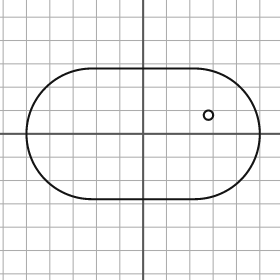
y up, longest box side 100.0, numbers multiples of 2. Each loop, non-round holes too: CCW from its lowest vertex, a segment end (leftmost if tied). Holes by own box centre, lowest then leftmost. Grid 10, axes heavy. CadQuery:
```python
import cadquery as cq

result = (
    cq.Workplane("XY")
    .moveTo(-22.0, -28.0)
    .lineTo(22.0, -28.0)
    .threePointArc((50.0, 0.0), (22.0, 28.0))
    .lineTo(-22.0, 28.0)
    .threePointArc((-50.0, 0.0), (-22.0, -28.0))
    .close()
    .moveTo(28.0, 8.0)
    .circle(2.0)
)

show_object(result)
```